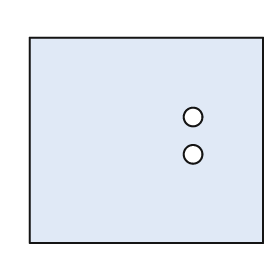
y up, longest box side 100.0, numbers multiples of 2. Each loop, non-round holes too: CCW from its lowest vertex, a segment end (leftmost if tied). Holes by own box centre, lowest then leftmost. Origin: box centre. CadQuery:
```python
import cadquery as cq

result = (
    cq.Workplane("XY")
    .moveTo(-50.0, -44.0)
    .lineTo(50.0, -44.0)
    .lineTo(50.0, 44.0)
    .lineTo(-50.0, 44.0)
    .close()
    .moveTo(20.0, -6.0)
    .circle(4.0)
    .moveTo(20.0, 10.0)
    .circle(4.0)
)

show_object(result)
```